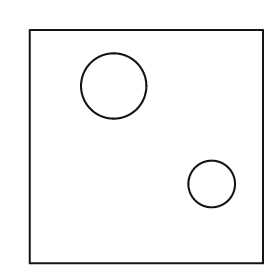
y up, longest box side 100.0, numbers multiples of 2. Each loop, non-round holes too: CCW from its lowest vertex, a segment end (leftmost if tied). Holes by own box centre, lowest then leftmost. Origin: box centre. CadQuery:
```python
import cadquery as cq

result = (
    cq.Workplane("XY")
    .moveTo(-50.0, -50.0)
    .lineTo(50.0, -50.0)
    .lineTo(50.0, 50.0)
    .lineTo(-50.0, 50.0)
    .close()
    .moveTo(28.0, -16.0)
    .circle(10.0)
    .moveTo(-14.0, 26.0)
    .circle(14.0)
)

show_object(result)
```